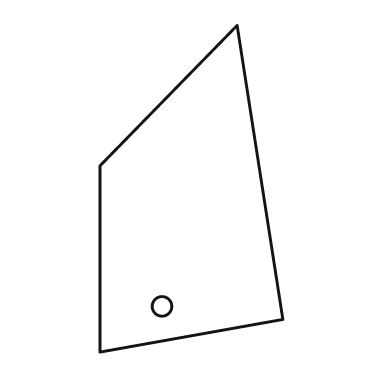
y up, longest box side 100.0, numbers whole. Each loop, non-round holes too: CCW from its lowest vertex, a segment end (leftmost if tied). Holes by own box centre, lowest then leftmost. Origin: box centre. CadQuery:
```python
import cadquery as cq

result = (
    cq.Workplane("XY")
    .moveTo(-28.0, -50.0)
    .lineTo(28.0, -40.0)
    .lineTo(14.0, 50.0)
    .lineTo(-28.0, 7.0)
    .close()
    .moveTo(-9.0, -36.0)
    .circle(3.0)
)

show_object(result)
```